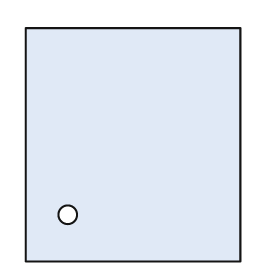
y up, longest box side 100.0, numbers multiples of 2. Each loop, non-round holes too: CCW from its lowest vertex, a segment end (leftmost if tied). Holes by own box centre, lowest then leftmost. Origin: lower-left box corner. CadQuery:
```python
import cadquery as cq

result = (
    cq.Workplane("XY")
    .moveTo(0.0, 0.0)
    .lineTo(92.0, 0.0)
    .lineTo(92.0, 100.0)
    .lineTo(0.0, 100.0)
    .close()
    .moveTo(18.0, 20.0)
    .circle(4.0)
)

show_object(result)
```